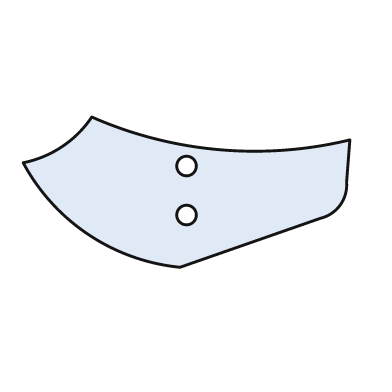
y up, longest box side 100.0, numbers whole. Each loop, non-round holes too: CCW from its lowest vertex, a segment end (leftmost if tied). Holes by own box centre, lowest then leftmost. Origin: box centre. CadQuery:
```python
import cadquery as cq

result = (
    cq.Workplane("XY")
    .moveTo(-2.0, -23.0)
    .lineTo(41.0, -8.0)
    .threePointArc((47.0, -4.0), (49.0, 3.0))
    .lineTo(50.0, 16.0)
    .threePointArc((10.0, 13.0), (-29.0, 23.0))
    .threePointArc((-38.0, 14.0), (-50.0, 9.0))
    .threePointArc((-30.0, -13.0), (-2.0, -23.0))
    .close()
    .moveTo(0.0, -7.0)
    .circle(3.0)
    .moveTo(0.0, 8.0)
    .circle(3.0)
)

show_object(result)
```